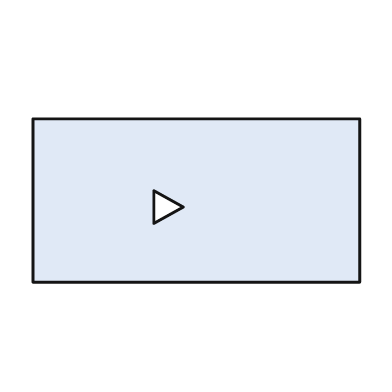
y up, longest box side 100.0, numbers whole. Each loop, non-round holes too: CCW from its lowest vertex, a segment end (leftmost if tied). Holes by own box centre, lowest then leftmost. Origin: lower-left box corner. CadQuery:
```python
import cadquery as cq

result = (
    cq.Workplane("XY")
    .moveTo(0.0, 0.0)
    .lineTo(100.0, 0.0)
    .lineTo(100.0, 50.0)
    .lineTo(0.0, 50.0)
    .close()
    .moveTo(37.0, 18.0)
    .lineTo(46.0, 23.0)
    .lineTo(37.0, 28.0)
    .close()
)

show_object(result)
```